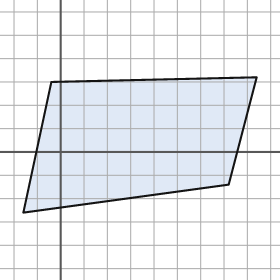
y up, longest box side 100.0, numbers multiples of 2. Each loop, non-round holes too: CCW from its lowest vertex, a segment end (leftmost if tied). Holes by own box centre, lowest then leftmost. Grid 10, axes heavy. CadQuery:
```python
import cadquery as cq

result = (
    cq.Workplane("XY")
    .moveTo(-16.0, -26.0)
    .lineTo(72.0, -14.0)
    .lineTo(84.0, 32.0)
    .lineTo(-4.0, 30.0)
    .close()
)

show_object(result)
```